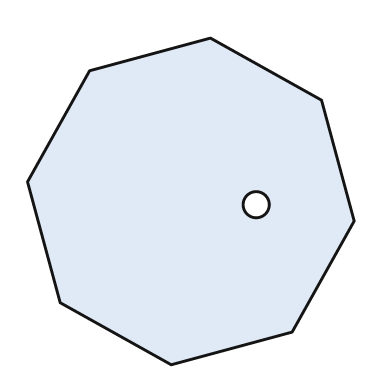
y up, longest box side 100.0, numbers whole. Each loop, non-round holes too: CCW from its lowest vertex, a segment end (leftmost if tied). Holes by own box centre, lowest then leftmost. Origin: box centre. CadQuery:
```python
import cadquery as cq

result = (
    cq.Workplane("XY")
    .moveTo(-6.0, -50.0)
    .lineTo(31.0, -40.0)
    .lineTo(50.0, -6.0)
    .lineTo(40.0, 31.0)
    .lineTo(6.0, 50.0)
    .lineTo(-31.0, 40.0)
    .lineTo(-50.0, 6.0)
    .lineTo(-40.0, -31.0)
    .close()
    .moveTo(20.0, -1.0)
    .circle(4.0)
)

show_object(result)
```